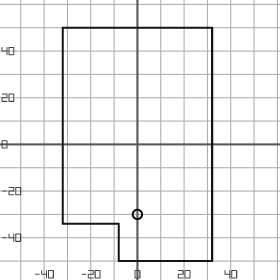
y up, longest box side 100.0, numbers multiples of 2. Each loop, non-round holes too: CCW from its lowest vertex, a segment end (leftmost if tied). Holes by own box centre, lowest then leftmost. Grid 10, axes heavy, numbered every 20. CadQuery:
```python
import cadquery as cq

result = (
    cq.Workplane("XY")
    .moveTo(-8.0, -50.0)
    .lineTo(32.0, -50.0)
    .lineTo(32.0, 50.0)
    .lineTo(-32.0, 50.0)
    .lineTo(-32.0, -34.0)
    .lineTo(-8.0, -34.0)
    .close()
    .moveTo(0.0, -30.0)
    .circle(2.0)
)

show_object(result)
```